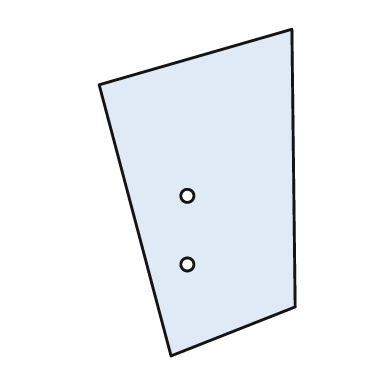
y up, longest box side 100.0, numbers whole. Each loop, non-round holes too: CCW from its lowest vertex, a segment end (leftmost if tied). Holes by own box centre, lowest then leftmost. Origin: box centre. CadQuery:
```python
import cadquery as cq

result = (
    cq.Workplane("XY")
    .moveTo(-8.0, -50.0)
    .lineTo(30.0, -35.0)
    .lineTo(29.0, 50.0)
    .lineTo(-30.0, 33.0)
    .close()
    .moveTo(-3.0, -22.0)
    .circle(2.0)
    .moveTo(-3.0, -1.0)
    .circle(2.0)
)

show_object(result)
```